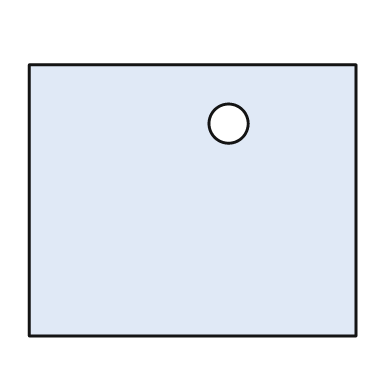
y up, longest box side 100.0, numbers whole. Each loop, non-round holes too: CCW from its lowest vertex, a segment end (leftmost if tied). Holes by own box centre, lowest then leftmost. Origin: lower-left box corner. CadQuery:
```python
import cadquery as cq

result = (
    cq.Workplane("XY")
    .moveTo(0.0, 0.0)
    .lineTo(100.0, 0.0)
    .lineTo(100.0, 83.0)
    .lineTo(0.0, 83.0)
    .close()
    .moveTo(61.0, 65.0)
    .circle(6.0)
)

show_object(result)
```